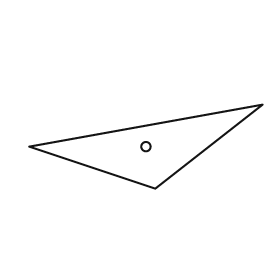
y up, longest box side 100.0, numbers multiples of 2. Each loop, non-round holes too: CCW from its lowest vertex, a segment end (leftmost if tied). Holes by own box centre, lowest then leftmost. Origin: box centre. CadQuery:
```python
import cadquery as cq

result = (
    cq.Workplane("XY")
    .moveTo(4.0, -18.0)
    .lineTo(50.0, 18.0)
    .lineTo(-50.0, 0.0)
    .close()
    .moveTo(0.0, 0.0)
    .circle(2.0)
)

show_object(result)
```